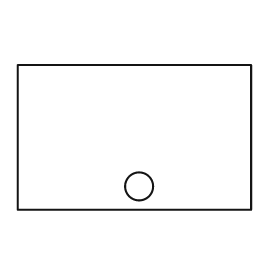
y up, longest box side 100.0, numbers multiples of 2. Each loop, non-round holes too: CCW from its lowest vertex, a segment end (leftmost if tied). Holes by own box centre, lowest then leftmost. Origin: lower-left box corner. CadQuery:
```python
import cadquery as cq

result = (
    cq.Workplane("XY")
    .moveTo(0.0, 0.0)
    .lineTo(100.0, 0.0)
    .lineTo(100.0, 62.0)
    .lineTo(0.0, 62.0)
    .close()
    .moveTo(52.0, 10.0)
    .circle(6.0)
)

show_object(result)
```